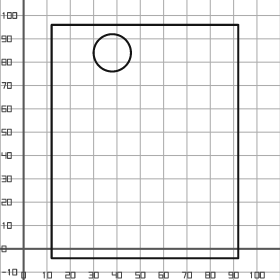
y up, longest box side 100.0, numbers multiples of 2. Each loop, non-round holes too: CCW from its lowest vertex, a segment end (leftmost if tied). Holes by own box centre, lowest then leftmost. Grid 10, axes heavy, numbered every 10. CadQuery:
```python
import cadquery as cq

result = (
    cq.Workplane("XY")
    .moveTo(12.0, -4.0)
    .lineTo(92.0, -4.0)
    .lineTo(92.0, 96.0)
    .lineTo(12.0, 96.0)
    .close()
    .moveTo(38.0, 84.0)
    .circle(8.0)
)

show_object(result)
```